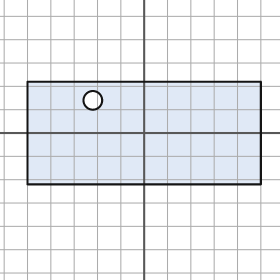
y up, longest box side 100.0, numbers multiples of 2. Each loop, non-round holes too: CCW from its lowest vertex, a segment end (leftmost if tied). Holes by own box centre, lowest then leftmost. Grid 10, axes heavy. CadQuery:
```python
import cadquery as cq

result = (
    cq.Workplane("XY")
    .moveTo(-50.0, -22.0)
    .lineTo(50.0, -22.0)
    .lineTo(50.0, 22.0)
    .lineTo(-50.0, 22.0)
    .close()
    .moveTo(-22.0, 14.0)
    .circle(4.0)
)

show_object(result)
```